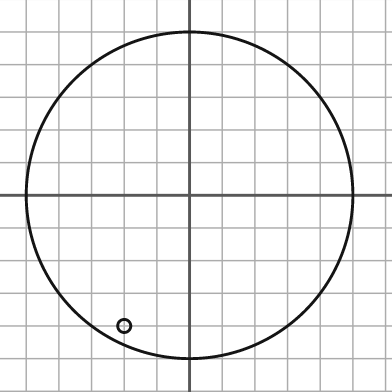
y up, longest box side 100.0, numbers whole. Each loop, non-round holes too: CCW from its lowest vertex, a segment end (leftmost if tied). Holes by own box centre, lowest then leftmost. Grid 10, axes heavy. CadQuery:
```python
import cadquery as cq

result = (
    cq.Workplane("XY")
    .moveTo(0.0, 0.0)
    .circle(50.0)
    .moveTo(-20.0, -40.0)
    .circle(2.0)
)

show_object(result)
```